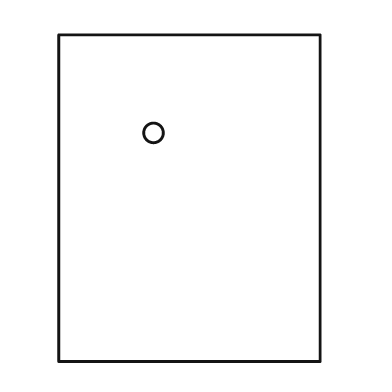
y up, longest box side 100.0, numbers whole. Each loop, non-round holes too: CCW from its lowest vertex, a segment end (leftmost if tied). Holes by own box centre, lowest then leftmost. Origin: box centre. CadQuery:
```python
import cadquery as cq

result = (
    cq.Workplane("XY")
    .moveTo(-40.0, -50.0)
    .lineTo(40.0, -50.0)
    .lineTo(40.0, 50.0)
    .lineTo(-40.0, 50.0)
    .close()
    .moveTo(-11.0, 20.0)
    .circle(3.0)
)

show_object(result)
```